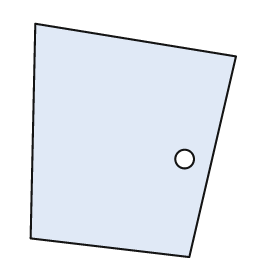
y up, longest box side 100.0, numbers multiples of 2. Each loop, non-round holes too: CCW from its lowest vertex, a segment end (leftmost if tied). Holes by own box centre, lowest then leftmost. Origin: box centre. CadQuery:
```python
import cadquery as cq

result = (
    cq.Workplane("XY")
    .moveTo(24.0, -50.0)
    .lineTo(44.0, 36.0)
    .lineTo(-42.0, 50.0)
    .lineTo(-44.0, -42.0)
    .close()
    .moveTo(22.0, -8.0)
    .circle(4.0)
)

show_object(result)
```